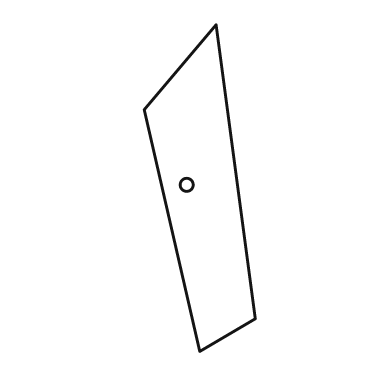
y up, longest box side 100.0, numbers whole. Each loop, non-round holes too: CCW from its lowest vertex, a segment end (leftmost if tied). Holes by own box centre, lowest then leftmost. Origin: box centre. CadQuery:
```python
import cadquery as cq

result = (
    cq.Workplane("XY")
    .moveTo(0.0, -50.0)
    .lineTo(17.0, -40.0)
    .lineTo(5.0, 50.0)
    .lineTo(-17.0, 24.0)
    .close()
    .moveTo(-4.0, 1.0)
    .circle(2.0)
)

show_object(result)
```